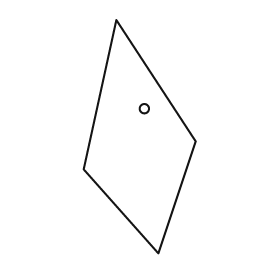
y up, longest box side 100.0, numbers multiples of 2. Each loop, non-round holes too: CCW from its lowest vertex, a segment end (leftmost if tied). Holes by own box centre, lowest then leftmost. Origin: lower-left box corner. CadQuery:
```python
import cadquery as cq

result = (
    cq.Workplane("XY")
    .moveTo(32.0, 0.0)
    .lineTo(48.0, 48.0)
    .lineTo(14.0, 100.0)
    .lineTo(0.0, 36.0)
    .close()
    .moveTo(26.0, 62.0)
    .circle(2.0)
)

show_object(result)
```